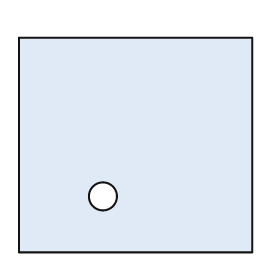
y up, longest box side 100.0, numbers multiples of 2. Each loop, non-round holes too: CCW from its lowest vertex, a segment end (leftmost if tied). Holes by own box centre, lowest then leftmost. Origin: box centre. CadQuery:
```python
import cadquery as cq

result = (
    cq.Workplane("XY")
    .moveTo(-50.0, -46.0)
    .lineTo(50.0, -46.0)
    .lineTo(50.0, 46.0)
    .lineTo(-50.0, 46.0)
    .close()
    .moveTo(-14.0, -22.0)
    .circle(6.0)
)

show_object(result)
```